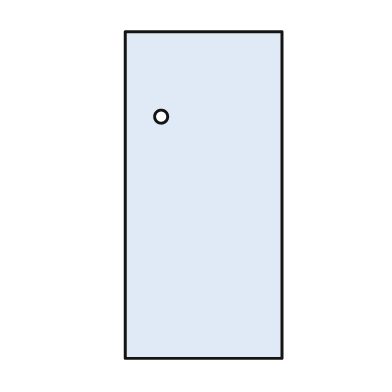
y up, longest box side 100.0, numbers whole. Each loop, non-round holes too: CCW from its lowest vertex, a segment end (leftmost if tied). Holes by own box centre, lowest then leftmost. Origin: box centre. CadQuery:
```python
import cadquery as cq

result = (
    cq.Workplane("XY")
    .moveTo(-24.0, -50.0)
    .lineTo(24.0, -50.0)
    .lineTo(24.0, 50.0)
    .lineTo(-24.0, 50.0)
    .close()
    .moveTo(-13.0, 24.0)
    .circle(2.0)
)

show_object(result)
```